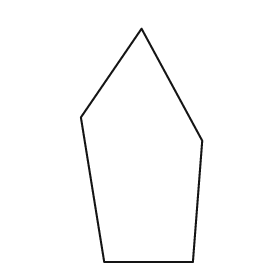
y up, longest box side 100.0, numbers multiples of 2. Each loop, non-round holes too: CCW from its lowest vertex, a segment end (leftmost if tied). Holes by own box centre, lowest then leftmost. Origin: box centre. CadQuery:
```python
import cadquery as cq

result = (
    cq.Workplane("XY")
    .moveTo(-16.0, -50.0)
    .lineTo(22.0, -50.0)
    .lineTo(26.0, 2.0)
    .lineTo(0.0, 50.0)
    .lineTo(-26.0, 12.0)
    .close()
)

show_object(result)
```